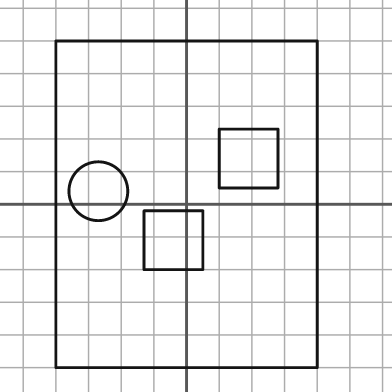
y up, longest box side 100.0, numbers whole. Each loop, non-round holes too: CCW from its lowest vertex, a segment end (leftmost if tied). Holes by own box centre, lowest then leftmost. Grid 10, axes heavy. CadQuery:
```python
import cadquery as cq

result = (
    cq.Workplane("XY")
    .moveTo(-40.0, -50.0)
    .lineTo(40.0, -50.0)
    .lineTo(40.0, 50.0)
    .lineTo(-40.0, 50.0)
    .close()
    .moveTo(-13.0, -20.0)
    .lineTo(5.0, -20.0)
    .lineTo(5.0, -2.0)
    .lineTo(-13.0, -2.0)
    .close()
    .moveTo(-27.0, 4.0)
    .circle(9.0)
    .moveTo(10.0, 5.0)
    .lineTo(28.0, 5.0)
    .lineTo(28.0, 23.0)
    .lineTo(10.0, 23.0)
    .close()
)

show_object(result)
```